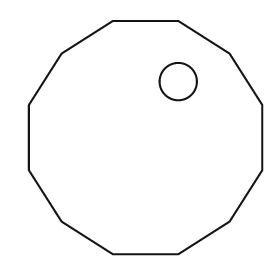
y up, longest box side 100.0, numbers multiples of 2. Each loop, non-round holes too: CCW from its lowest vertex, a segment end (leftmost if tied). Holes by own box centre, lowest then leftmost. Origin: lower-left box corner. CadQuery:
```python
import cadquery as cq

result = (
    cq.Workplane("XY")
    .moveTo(36.0, 0.0)
    .lineTo(64.0, 0.0)
    .lineTo(86.0, 14.0)
    .lineTo(100.0, 36.0)
    .lineTo(100.0, 64.0)
    .lineTo(86.0, 86.0)
    .lineTo(64.0, 100.0)
    .lineTo(36.0, 100.0)
    .lineTo(14.0, 86.0)
    .lineTo(0.0, 64.0)
    .lineTo(0.0, 36.0)
    .lineTo(14.0, 14.0)
    .close()
    .moveTo(64.0, 74.0)
    .circle(8.0)
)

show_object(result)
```